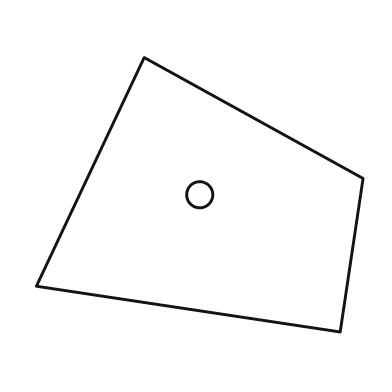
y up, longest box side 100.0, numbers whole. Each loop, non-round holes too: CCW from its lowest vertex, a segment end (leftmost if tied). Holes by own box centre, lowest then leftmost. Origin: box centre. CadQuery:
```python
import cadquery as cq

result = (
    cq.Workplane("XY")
    .moveTo(43.0, -42.0)
    .lineTo(50.0, 5.0)
    .lineTo(-17.0, 42.0)
    .lineTo(-50.0, -28.0)
    .close()
    .moveTo(0.0, 0.0)
    .circle(4.0)
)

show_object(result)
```